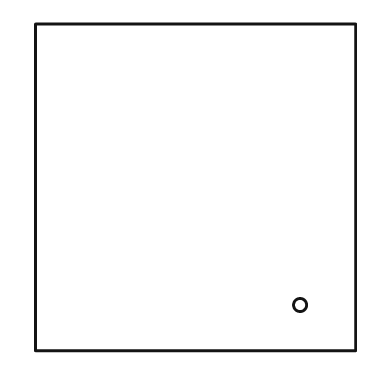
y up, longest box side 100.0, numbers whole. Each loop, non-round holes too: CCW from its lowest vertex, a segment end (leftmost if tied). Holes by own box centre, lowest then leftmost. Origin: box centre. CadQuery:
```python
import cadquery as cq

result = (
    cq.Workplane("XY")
    .moveTo(-49.0, -50.0)
    .lineTo(49.0, -50.0)
    .lineTo(49.0, 50.0)
    .lineTo(-49.0, 50.0)
    .close()
    .moveTo(32.0, -36.0)
    .circle(2.0)
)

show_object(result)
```